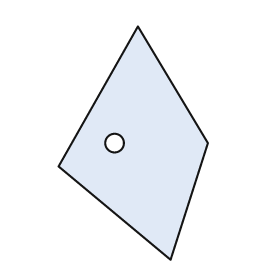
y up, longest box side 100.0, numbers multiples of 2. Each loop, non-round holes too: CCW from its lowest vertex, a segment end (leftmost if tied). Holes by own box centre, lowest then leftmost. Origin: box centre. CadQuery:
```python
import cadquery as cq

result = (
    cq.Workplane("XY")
    .moveTo(16.0, -50.0)
    .lineTo(32.0, 0.0)
    .lineTo(2.0, 50.0)
    .lineTo(-32.0, -10.0)
    .close()
    .moveTo(-8.0, 0.0)
    .circle(4.0)
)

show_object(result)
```